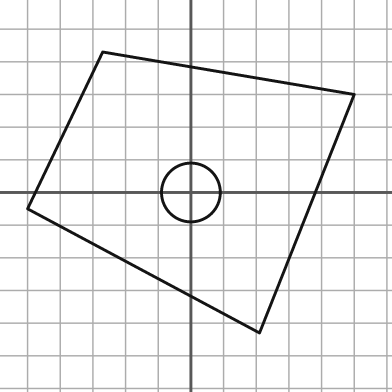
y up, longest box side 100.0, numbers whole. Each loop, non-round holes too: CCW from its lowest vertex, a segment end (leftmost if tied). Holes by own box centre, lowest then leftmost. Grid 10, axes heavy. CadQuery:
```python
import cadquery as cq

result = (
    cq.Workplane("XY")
    .moveTo(21.0, -43.0)
    .lineTo(50.0, 30.0)
    .lineTo(-27.0, 43.0)
    .lineTo(-50.0, -5.0)
    .close()
    .moveTo(0.0, 0.0)
    .circle(9.0)
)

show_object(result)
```